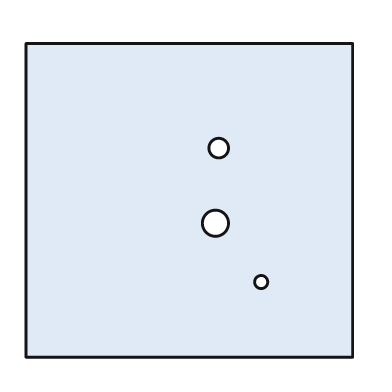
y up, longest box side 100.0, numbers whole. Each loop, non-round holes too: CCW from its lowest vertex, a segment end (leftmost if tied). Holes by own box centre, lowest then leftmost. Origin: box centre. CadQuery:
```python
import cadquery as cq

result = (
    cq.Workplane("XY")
    .moveTo(-50.0, -48.0)
    .lineTo(50.0, -48.0)
    .lineTo(50.0, 48.0)
    .lineTo(-50.0, 48.0)
    .close()
    .moveTo(22.0, -25.0)
    .circle(2.0)
    .moveTo(8.0, -7.0)
    .circle(4.0)
    .moveTo(9.0, 16.0)
    .circle(3.0)
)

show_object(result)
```